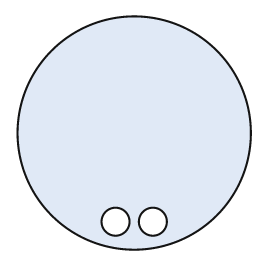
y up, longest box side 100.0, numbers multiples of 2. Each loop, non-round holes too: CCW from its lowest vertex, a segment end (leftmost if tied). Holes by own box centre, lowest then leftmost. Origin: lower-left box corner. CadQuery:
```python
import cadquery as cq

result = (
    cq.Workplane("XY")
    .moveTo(50.0, 50.0)
    .circle(50.0)
    .moveTo(42.0, 12.0)
    .circle(6.0)
    .moveTo(58.0, 12.0)
    .circle(6.0)
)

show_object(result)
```